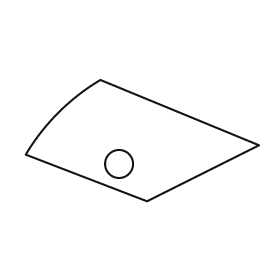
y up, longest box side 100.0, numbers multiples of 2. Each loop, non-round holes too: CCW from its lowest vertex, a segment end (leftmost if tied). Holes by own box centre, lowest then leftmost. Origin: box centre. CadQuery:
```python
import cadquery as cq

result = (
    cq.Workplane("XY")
    .moveTo(2.0, -26.0)
    .lineTo(50.0, -2.0)
    .lineTo(-18.0, 26.0)
    .threePointArc((-36.0, 12.0), (-50.0, -6.0))
    .close()
    .moveTo(-10.0, -10.0)
    .circle(6.0)
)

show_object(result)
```